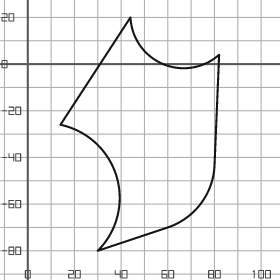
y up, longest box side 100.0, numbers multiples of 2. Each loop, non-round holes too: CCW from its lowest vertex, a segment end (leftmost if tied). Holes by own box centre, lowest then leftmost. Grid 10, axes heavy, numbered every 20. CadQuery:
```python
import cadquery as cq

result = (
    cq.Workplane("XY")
    .moveTo(30.0, -80.0)
    .lineTo(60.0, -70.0)
    .threePointArc((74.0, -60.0), (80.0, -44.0))
    .lineTo(82.0, 4.0)
    .threePointArc((58.0, 0.0), (44.0, 20.0))
    .lineTo(14.0, -26.0)
    .threePointArc((38.0, -48.0), (30.0, -80.0))
    .close()
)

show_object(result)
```